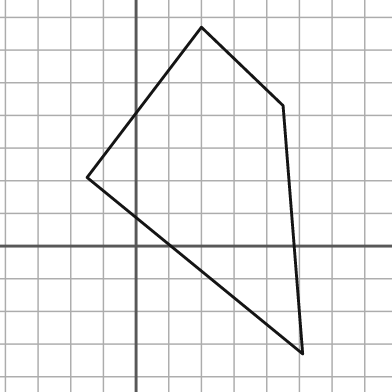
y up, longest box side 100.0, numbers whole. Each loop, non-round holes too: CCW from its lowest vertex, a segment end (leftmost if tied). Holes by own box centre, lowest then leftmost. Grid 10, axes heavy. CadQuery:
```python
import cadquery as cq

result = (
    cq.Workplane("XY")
    .moveTo(51.0, -33.0)
    .lineTo(45.0, 43.0)
    .lineTo(20.0, 67.0)
    .lineTo(-15.0, 21.0)
    .close()
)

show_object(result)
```